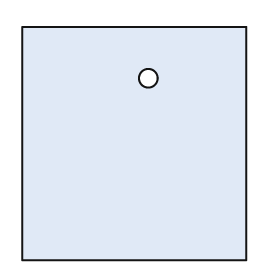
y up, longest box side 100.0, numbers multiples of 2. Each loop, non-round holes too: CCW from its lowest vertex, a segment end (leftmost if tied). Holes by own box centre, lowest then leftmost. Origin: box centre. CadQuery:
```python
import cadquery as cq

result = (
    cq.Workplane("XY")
    .moveTo(-48.0, -50.0)
    .lineTo(48.0, -50.0)
    .lineTo(48.0, 50.0)
    .lineTo(-48.0, 50.0)
    .close()
    .moveTo(6.0, 28.0)
    .circle(4.0)
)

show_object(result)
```